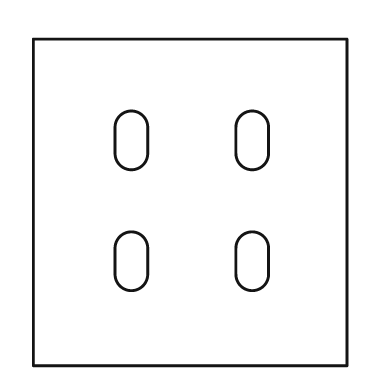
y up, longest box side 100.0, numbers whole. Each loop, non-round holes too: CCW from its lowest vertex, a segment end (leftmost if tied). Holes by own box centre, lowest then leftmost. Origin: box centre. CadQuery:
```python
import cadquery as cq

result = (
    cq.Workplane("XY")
    .moveTo(-48.0, -50.0)
    .lineTo(48.0, -50.0)
    .lineTo(48.0, 50.0)
    .lineTo(-48.0, 50.0)
    .close()
    .moveTo(-23.0, -22.0)
    .threePointArc((-18.0, -27.0), (-13.0, -22.0))
    .lineTo(-13.0, -14.0)
    .threePointArc((-18.0, -9.0), (-23.0, -14.0))
    .close()
    .moveTo(14.0, -22.0)
    .threePointArc((19.0, -27.0), (24.0, -22.0))
    .lineTo(24.0, -14.0)
    .threePointArc((19.0, -9.0), (14.0, -14.0))
    .close()
    .moveTo(-23.0, 15.0)
    .threePointArc((-18.0, 10.0), (-13.0, 15.0))
    .lineTo(-13.0, 23.0)
    .threePointArc((-18.0, 28.0), (-23.0, 23.0))
    .close()
    .moveTo(14.0, 15.0)
    .threePointArc((19.0, 10.0), (24.0, 15.0))
    .lineTo(24.0, 23.0)
    .threePointArc((19.0, 28.0), (14.0, 23.0))
    .close()
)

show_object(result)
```